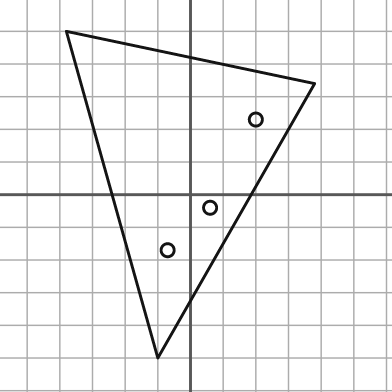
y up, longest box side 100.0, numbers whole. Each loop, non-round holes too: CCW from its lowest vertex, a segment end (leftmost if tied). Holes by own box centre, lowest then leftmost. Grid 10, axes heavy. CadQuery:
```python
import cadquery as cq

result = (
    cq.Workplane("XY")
    .moveTo(-10.0, -50.0)
    .lineTo(38.0, 34.0)
    .lineTo(-38.0, 50.0)
    .close()
    .moveTo(-7.0, -17.0)
    .circle(2.0)
    .moveTo(6.0, -4.0)
    .circle(2.0)
    .moveTo(20.0, 23.0)
    .circle(2.0)
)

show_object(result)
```